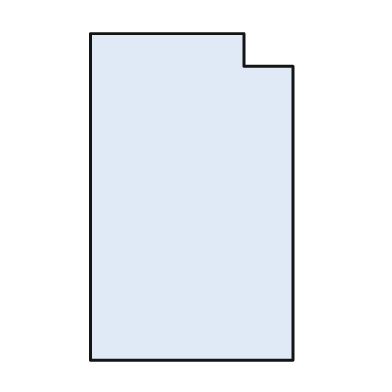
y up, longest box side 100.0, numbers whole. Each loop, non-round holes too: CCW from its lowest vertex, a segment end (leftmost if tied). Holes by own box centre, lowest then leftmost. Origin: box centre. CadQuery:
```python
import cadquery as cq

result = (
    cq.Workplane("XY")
    .moveTo(-31.0, -50.0)
    .lineTo(31.0, -50.0)
    .lineTo(31.0, 40.0)
    .lineTo(16.0, 40.0)
    .lineTo(16.0, 50.0)
    .lineTo(-31.0, 50.0)
    .close()
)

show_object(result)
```